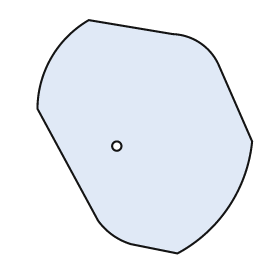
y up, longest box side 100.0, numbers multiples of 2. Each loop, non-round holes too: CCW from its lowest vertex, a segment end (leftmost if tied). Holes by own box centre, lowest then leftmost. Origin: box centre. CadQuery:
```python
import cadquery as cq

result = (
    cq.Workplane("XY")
    .moveTo(14.0, -50.0)
    .threePointArc((36.0, -30.0), (46.0, -2.0))
    .lineTo(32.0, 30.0)
    .threePointArc((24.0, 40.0), (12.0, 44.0))
    .lineTo(-24.0, 50.0)
    .threePointArc((-40.0, 34.0), (-46.0, 12.0))
    .lineTo(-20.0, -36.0)
    .threePointArc((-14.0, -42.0), (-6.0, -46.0))
    .close()
    .moveTo(-12.0, -4.0)
    .circle(2.0)
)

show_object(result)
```